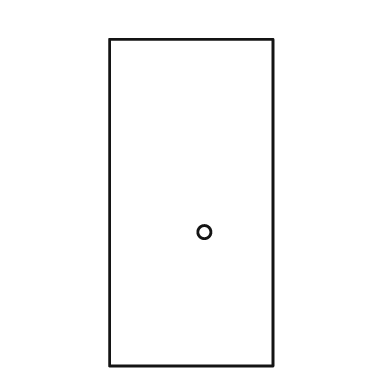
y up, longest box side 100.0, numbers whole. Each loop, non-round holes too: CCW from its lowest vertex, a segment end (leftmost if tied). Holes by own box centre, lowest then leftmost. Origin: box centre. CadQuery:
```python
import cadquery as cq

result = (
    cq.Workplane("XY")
    .moveTo(-25.0, -50.0)
    .lineTo(25.0, -50.0)
    .lineTo(25.0, 50.0)
    .lineTo(-25.0, 50.0)
    .close()
    .moveTo(4.0, -9.0)
    .circle(2.0)
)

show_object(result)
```